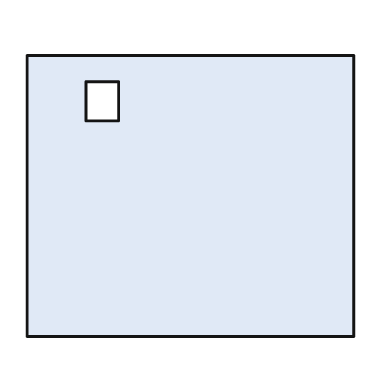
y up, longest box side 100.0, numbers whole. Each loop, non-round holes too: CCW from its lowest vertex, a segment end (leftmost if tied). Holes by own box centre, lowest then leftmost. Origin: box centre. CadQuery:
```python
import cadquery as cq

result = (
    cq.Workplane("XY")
    .moveTo(-50.0, -43.0)
    .lineTo(50.0, -43.0)
    .lineTo(50.0, 43.0)
    .lineTo(-50.0, 43.0)
    .close()
    .moveTo(-32.0, 23.0)
    .lineTo(-22.0, 23.0)
    .lineTo(-22.0, 35.0)
    .lineTo(-32.0, 35.0)
    .close()
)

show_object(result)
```